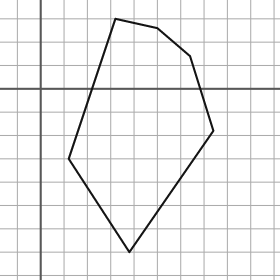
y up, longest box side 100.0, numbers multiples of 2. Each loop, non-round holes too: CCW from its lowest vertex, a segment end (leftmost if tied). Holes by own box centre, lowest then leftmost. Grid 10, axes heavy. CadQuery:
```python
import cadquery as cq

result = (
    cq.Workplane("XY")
    .moveTo(38.0, -70.0)
    .lineTo(74.0, -18.0)
    .lineTo(64.0, 14.0)
    .lineTo(50.0, 26.0)
    .lineTo(32.0, 30.0)
    .lineTo(12.0, -30.0)
    .close()
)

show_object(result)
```